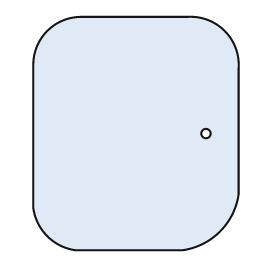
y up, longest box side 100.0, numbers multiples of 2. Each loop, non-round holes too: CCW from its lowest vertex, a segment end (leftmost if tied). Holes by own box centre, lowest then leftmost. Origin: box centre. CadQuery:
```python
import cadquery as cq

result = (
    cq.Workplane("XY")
    .moveTo(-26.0, -50.0)
    .lineTo(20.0, -50.0)
    .threePointArc((36.0, -42.0), (44.0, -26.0))
    .lineTo(44.0, 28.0)
    .threePointArc((38.0, 44.0), (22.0, 50.0))
    .lineTo(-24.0, 50.0)
    .threePointArc((-38.0, 44.0), (-44.0, 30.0))
    .lineTo(-44.0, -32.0)
    .threePointArc((-38.0, -44.0), (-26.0, -50.0))
    .close()
    .moveTo(30.0, 0.0)
    .circle(2.0)
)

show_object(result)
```